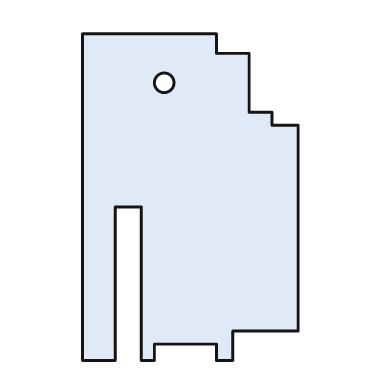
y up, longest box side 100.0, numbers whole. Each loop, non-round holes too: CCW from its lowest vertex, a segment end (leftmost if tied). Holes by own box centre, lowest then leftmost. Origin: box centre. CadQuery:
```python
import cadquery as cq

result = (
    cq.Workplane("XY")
    .moveTo(-33.0, -50.0)
    .lineTo(-23.0, -50.0)
    .lineTo(-23.0, -3.0)
    .lineTo(-15.0, -3.0)
    .lineTo(-15.0, -50.0)
    .lineTo(-11.0, -50.0)
    .lineTo(-11.0, -45.0)
    .lineTo(8.0, -45.0)
    .lineTo(8.0, -50.0)
    .lineTo(13.0, -50.0)
    .lineTo(13.0, -41.0)
    .lineTo(33.0, -41.0)
    .lineTo(33.0, 22.0)
    .lineTo(25.0, 22.0)
    .lineTo(25.0, 26.0)
    .lineTo(18.0, 26.0)
    .lineTo(18.0, 44.0)
    .lineTo(8.0, 44.0)
    .lineTo(8.0, 50.0)
    .lineTo(-33.0, 50.0)
    .close()
    .moveTo(-8.0, 35.0)
    .circle(3.0)
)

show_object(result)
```